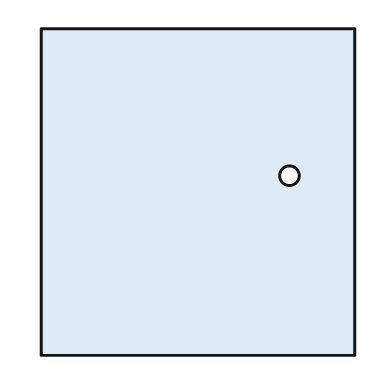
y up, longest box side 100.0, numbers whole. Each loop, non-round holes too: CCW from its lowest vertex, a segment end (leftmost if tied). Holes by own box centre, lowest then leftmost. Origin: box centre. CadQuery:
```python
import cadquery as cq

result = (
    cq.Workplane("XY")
    .moveTo(-48.0, -50.0)
    .lineTo(48.0, -50.0)
    .lineTo(48.0, 50.0)
    .lineTo(-48.0, 50.0)
    .close()
    .moveTo(28.0, 5.0)
    .circle(3.0)
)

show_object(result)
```